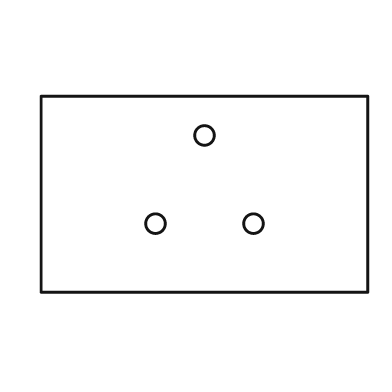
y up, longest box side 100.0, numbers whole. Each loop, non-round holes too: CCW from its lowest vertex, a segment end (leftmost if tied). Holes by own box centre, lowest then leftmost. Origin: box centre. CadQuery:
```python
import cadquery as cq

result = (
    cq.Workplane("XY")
    .moveTo(-50.0, -30.0)
    .lineTo(50.0, -30.0)
    .lineTo(50.0, 30.0)
    .lineTo(-50.0, 30.0)
    .close()
    .moveTo(-15.0, -9.0)
    .circle(3.0)
    .moveTo(15.0, -9.0)
    .circle(3.0)
    .moveTo(0.0, 18.0)
    .circle(3.0)
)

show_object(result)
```